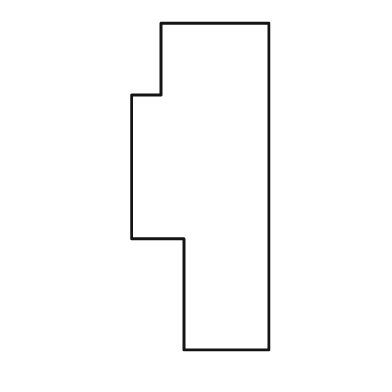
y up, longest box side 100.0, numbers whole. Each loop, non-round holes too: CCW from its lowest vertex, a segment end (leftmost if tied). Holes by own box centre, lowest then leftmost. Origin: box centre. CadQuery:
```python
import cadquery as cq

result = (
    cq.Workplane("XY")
    .moveTo(-5.0, -50.0)
    .lineTo(21.0, -50.0)
    .lineTo(21.0, 50.0)
    .lineTo(-12.0, 50.0)
    .lineTo(-12.0, 28.0)
    .lineTo(-21.0, 28.0)
    .lineTo(-21.0, -16.0)
    .lineTo(-5.0, -16.0)
    .close()
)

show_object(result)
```